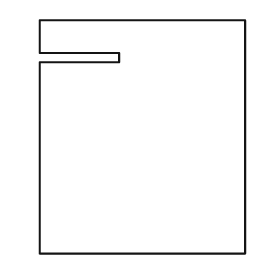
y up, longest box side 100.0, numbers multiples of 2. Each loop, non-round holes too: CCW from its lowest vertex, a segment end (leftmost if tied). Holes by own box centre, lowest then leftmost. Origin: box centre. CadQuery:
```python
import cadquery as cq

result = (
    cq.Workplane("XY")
    .moveTo(-44.0, -50.0)
    .lineTo(44.0, -50.0)
    .lineTo(44.0, 50.0)
    .lineTo(-44.0, 50.0)
    .lineTo(-44.0, 36.0)
    .lineTo(-10.0, 36.0)
    .lineTo(-10.0, 32.0)
    .lineTo(-44.0, 32.0)
    .close()
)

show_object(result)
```